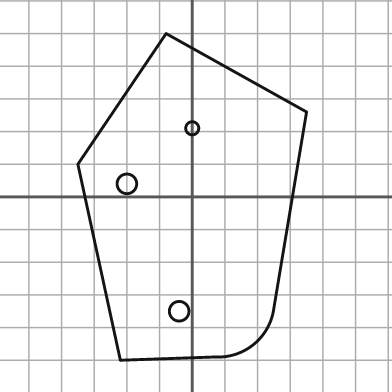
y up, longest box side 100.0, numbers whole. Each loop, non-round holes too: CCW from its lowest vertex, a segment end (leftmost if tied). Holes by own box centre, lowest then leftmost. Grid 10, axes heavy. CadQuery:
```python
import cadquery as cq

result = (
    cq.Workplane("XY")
    .moveTo(-22.0, -50.0)
    .lineTo(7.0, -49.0)
    .threePointArc((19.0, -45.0), (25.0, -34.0))
    .lineTo(35.0, 26.0)
    .lineTo(-8.0, 50.0)
    .lineTo(-35.0, 10.0)
    .close()
    .moveTo(-4.0, -35.0)
    .circle(3.0)
    .moveTo(-20.0, 4.0)
    .circle(3.0)
    .moveTo(0.0, 21.0)
    .circle(2.0)
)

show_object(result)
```